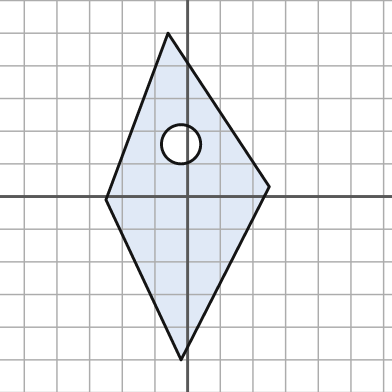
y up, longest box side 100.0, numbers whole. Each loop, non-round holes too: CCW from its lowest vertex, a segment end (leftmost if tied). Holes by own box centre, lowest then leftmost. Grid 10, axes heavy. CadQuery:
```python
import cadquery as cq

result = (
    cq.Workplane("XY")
    .moveTo(-2.0, -50.0)
    .lineTo(25.0, 3.0)
    .lineTo(-6.0, 50.0)
    .lineTo(-25.0, -1.0)
    .close()
    .moveTo(-2.0, 16.0)
    .circle(6.0)
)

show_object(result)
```